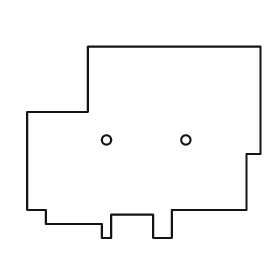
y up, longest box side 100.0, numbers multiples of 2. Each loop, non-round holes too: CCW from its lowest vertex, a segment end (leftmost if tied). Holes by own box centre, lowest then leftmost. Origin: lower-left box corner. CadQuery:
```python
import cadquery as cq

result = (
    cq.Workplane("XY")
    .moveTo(32.0, 0.0)
    .lineTo(36.0, 0.0)
    .lineTo(36.0, 10.0)
    .lineTo(54.0, 10.0)
    .lineTo(54.0, 0.0)
    .lineTo(62.0, 0.0)
    .lineTo(62.0, 12.0)
    .lineTo(94.0, 12.0)
    .lineTo(94.0, 36.0)
    .lineTo(100.0, 36.0)
    .lineTo(100.0, 82.0)
    .lineTo(26.0, 82.0)
    .lineTo(26.0, 54.0)
    .lineTo(0.0, 54.0)
    .lineTo(0.0, 12.0)
    .lineTo(8.0, 12.0)
    .lineTo(8.0, 6.0)
    .lineTo(32.0, 6.0)
    .close()
    .moveTo(34.0, 42.0)
    .circle(2.0)
    .moveTo(68.0, 42.0)
    .circle(2.0)
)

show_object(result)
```